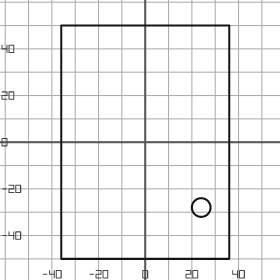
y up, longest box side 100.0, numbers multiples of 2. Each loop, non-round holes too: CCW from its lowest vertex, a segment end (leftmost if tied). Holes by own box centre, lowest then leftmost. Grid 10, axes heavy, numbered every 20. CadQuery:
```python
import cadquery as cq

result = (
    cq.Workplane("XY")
    .moveTo(-36.0, -50.0)
    .lineTo(36.0, -50.0)
    .lineTo(36.0, 50.0)
    .lineTo(-36.0, 50.0)
    .close()
    .moveTo(24.0, -28.0)
    .circle(4.0)
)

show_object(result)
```